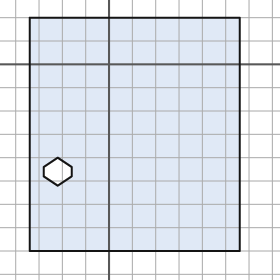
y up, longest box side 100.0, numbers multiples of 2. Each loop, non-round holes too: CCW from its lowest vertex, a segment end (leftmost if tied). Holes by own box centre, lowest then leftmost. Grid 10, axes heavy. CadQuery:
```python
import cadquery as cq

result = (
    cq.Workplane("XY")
    .moveTo(-34.0, -80.0)
    .lineTo(56.0, -80.0)
    .lineTo(56.0, 20.0)
    .lineTo(-34.0, 20.0)
    .close()
    .moveTo(-22.0, -52.0)
    .lineTo(-16.0, -48.0)
    .lineTo(-16.0, -44.0)
    .lineTo(-22.0, -40.0)
    .lineTo(-28.0, -44.0)
    .lineTo(-28.0, -48.0)
    .close()
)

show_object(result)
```